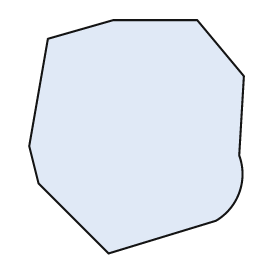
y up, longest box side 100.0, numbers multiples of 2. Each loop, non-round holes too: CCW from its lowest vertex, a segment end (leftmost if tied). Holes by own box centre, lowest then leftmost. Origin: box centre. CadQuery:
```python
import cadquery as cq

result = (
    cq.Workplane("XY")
    .moveTo(-12.0, -50.0)
    .lineTo(34.0, -36.0)
    .threePointArc((44.0, -24.0), (44.0, -8.0))
    .lineTo(46.0, 26.0)
    .lineTo(26.0, 50.0)
    .lineTo(-10.0, 50.0)
    .lineTo(-38.0, 42.0)
    .lineTo(-46.0, -4.0)
    .lineTo(-42.0, -20.0)
    .close()
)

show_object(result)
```